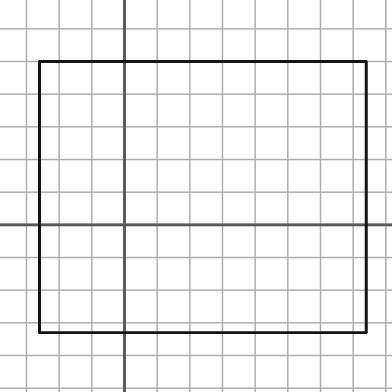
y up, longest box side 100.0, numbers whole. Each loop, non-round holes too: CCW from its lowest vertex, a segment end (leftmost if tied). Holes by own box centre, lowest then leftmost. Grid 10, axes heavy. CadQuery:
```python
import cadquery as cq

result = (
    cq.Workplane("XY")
    .moveTo(-26.0, -33.0)
    .lineTo(74.0, -33.0)
    .lineTo(74.0, 50.0)
    .lineTo(-26.0, 50.0)
    .close()
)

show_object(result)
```